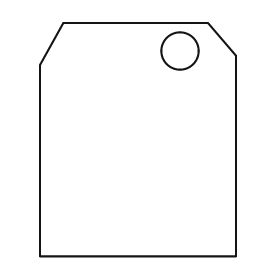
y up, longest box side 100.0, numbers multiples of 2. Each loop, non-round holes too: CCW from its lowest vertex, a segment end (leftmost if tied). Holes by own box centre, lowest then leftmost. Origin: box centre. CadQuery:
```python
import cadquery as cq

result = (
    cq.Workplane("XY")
    .moveTo(-42.0, -50.0)
    .lineTo(42.0, -50.0)
    .lineTo(42.0, 36.0)
    .lineTo(30.0, 50.0)
    .lineTo(-32.0, 50.0)
    .lineTo(-42.0, 32.0)
    .close()
    .moveTo(18.0, 38.0)
    .circle(8.0)
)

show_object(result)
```